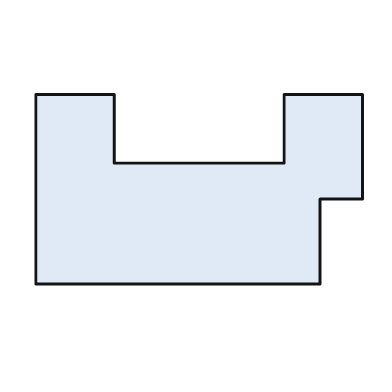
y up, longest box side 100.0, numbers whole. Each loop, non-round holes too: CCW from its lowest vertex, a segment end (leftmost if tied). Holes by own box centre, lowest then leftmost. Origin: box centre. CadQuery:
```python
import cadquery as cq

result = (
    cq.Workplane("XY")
    .moveTo(-50.0, -29.0)
    .lineTo(37.0, -29.0)
    .lineTo(37.0, -3.0)
    .lineTo(50.0, -3.0)
    .lineTo(50.0, 29.0)
    .lineTo(26.0, 29.0)
    .lineTo(26.0, 8.0)
    .lineTo(-26.0, 8.0)
    .lineTo(-26.0, 29.0)
    .lineTo(-50.0, 29.0)
    .close()
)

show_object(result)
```